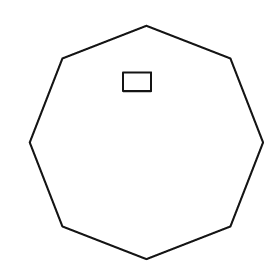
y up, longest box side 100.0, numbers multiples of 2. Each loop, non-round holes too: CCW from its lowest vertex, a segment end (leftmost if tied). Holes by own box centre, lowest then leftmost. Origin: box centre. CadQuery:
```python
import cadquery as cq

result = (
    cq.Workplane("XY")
    .moveTo(0.0, -50.0)
    .lineTo(36.0, -36.0)
    .lineTo(50.0, 0.0)
    .lineTo(36.0, 36.0)
    .lineTo(0.0, 50.0)
    .lineTo(-36.0, 36.0)
    .lineTo(-50.0, 0.0)
    .lineTo(-36.0, -36.0)
    .close()
    .moveTo(-10.0, 22.0)
    .lineTo(2.0, 22.0)
    .lineTo(2.0, 30.0)
    .lineTo(-10.0, 30.0)
    .close()
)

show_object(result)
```